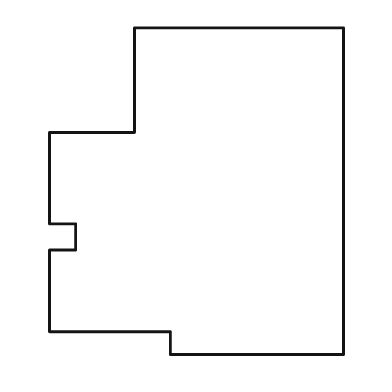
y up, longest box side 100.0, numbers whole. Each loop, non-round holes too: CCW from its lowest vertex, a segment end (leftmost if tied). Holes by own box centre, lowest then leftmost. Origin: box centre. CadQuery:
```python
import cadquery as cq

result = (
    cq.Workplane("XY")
    .moveTo(-8.0, -50.0)
    .lineTo(45.0, -50.0)
    .lineTo(45.0, 50.0)
    .lineTo(-19.0, 50.0)
    .lineTo(-19.0, 18.0)
    .lineTo(-45.0, 18.0)
    .lineTo(-45.0, -10.0)
    .lineTo(-37.0, -10.0)
    .lineTo(-37.0, -18.0)
    .lineTo(-45.0, -18.0)
    .lineTo(-45.0, -43.0)
    .lineTo(-8.0, -43.0)
    .close()
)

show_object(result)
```